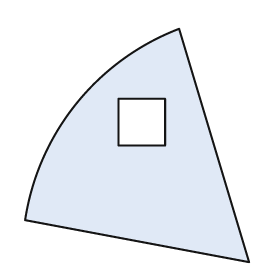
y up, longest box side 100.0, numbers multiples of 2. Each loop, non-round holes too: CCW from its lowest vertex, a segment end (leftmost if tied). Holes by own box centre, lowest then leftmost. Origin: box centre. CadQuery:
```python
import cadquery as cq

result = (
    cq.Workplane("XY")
    .moveTo(48.0, -50.0)
    .lineTo(18.0, 50.0)
    .threePointArc((-26.0, 18.0), (-48.0, -32.0))
    .close()
    .moveTo(-8.0, 0.0)
    .lineTo(12.0, 0.0)
    .lineTo(12.0, 20.0)
    .lineTo(-8.0, 20.0)
    .close()
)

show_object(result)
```